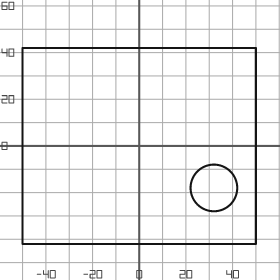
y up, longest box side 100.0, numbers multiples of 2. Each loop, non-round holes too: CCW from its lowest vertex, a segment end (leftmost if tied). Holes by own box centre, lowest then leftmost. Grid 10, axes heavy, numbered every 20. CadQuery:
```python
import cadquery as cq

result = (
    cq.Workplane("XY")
    .moveTo(-50.0, -42.0)
    .lineTo(50.0, -42.0)
    .lineTo(50.0, 42.0)
    .lineTo(-50.0, 42.0)
    .close()
    .moveTo(32.0, -18.0)
    .circle(10.0)
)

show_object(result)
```